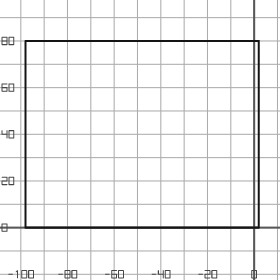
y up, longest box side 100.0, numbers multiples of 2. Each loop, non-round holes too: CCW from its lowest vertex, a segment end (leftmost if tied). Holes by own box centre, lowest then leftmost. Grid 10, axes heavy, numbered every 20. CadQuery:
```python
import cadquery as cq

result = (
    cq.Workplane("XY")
    .moveTo(-98.0, 0.0)
    .lineTo(2.0, 0.0)
    .lineTo(2.0, 80.0)
    .lineTo(-98.0, 80.0)
    .close()
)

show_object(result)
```